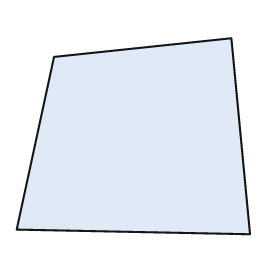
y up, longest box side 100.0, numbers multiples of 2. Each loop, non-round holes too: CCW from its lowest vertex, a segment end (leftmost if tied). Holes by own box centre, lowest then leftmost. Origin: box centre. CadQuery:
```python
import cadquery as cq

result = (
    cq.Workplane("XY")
    .moveTo(50.0, -42.0)
    .lineTo(42.0, 42.0)
    .lineTo(-34.0, 34.0)
    .lineTo(-50.0, -40.0)
    .close()
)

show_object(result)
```